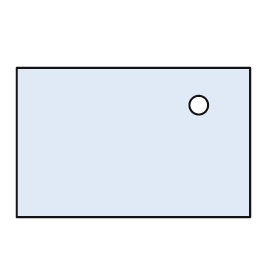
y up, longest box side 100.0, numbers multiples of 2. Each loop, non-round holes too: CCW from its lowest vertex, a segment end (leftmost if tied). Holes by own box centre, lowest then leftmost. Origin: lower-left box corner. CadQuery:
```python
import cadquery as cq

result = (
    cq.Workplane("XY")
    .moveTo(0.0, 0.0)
    .lineTo(100.0, 0.0)
    .lineTo(100.0, 64.0)
    .lineTo(0.0, 64.0)
    .close()
    .moveTo(78.0, 48.0)
    .circle(4.0)
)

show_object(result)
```